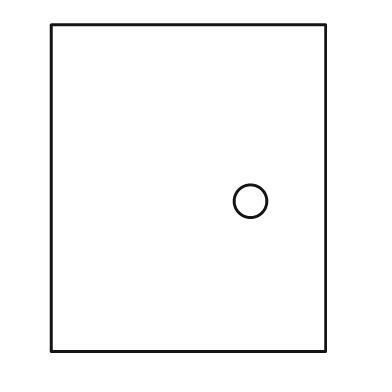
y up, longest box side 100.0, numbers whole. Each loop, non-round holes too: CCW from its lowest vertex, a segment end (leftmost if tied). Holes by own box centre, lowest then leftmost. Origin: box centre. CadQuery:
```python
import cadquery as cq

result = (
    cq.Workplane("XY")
    .moveTo(-42.0, -50.0)
    .lineTo(42.0, -50.0)
    .lineTo(42.0, 50.0)
    .lineTo(-42.0, 50.0)
    .close()
    .moveTo(19.0, -4.0)
    .circle(5.0)
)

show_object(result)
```